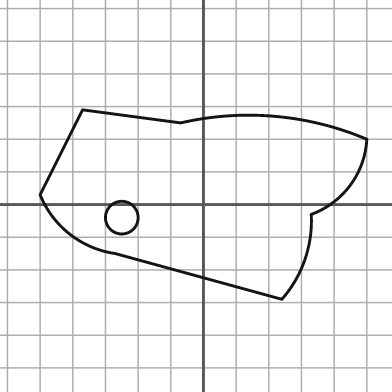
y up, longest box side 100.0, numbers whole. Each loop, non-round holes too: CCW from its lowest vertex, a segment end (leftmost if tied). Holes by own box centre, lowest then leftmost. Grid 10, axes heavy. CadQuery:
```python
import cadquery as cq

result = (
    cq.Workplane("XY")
    .moveTo(24.0, -29.0)
    .threePointArc((31.0, -17.0), (33.0, -3.0))
    .threePointArc((45.0, 6.0), (50.0, 20.0))
    .threePointArc((22.0, 27.0), (-7.0, 25.0))
    .lineTo(-37.0, 29.0)
    .lineTo(-50.0, 3.0)
    .threePointArc((-41.0, -9.0), (-27.0, -15.0))
    .close()
    .moveTo(-25.0, -4.0)
    .circle(5.0)
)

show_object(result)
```